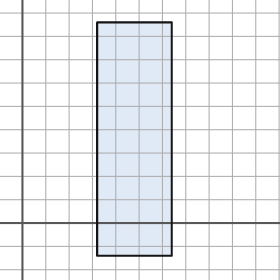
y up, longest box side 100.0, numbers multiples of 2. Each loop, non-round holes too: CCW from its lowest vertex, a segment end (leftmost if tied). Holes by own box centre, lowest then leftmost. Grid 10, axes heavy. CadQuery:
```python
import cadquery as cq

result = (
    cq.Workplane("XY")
    .moveTo(32.0, -14.0)
    .lineTo(64.0, -14.0)
    .lineTo(64.0, 86.0)
    .lineTo(32.0, 86.0)
    .close()
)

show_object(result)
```